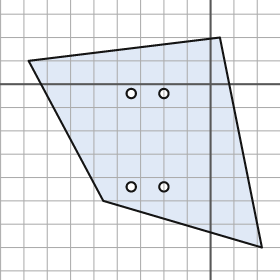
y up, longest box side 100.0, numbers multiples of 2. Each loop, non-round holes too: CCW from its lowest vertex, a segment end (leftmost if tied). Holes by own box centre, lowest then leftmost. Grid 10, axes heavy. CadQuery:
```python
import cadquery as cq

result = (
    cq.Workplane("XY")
    .moveTo(22.0, -70.0)
    .lineTo(4.0, 20.0)
    .lineTo(-78.0, 10.0)
    .lineTo(-46.0, -50.0)
    .close()
    .moveTo(-34.0, -44.0)
    .circle(2.0)
    .moveTo(-20.0, -44.0)
    .circle(2.0)
    .moveTo(-34.0, -4.0)
    .circle(2.0)
    .moveTo(-20.0, -4.0)
    .circle(2.0)
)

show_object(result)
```